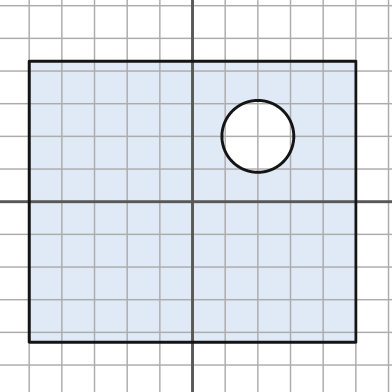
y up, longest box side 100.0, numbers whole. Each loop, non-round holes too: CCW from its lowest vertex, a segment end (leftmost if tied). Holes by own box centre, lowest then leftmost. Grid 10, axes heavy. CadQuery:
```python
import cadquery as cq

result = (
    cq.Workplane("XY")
    .moveTo(-50.0, -43.0)
    .lineTo(50.0, -43.0)
    .lineTo(50.0, 43.0)
    .lineTo(-50.0, 43.0)
    .close()
    .moveTo(20.0, 20.0)
    .circle(11.0)
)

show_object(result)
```